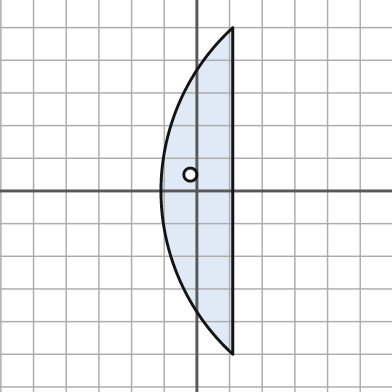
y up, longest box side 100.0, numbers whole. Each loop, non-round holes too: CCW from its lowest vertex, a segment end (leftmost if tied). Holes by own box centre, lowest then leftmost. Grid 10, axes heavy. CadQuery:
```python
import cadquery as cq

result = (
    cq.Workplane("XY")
    .moveTo(11.0, -50.0)
    .lineTo(11.0, 50.0)
    .threePointArc((-11.0, 0.0), (11.0, -50.0))
    .close()
    .moveTo(-2.0, 5.0)
    .circle(2.0)
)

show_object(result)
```